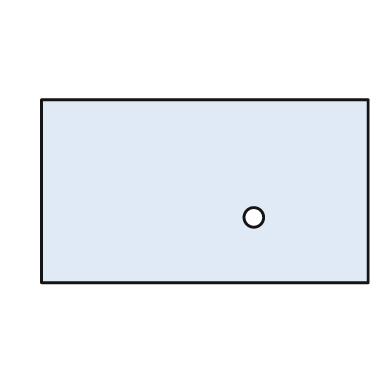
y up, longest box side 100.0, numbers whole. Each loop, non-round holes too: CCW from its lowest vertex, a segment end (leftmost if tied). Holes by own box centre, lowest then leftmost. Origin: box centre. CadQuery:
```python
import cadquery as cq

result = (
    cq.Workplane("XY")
    .moveTo(-50.0, -28.0)
    .lineTo(50.0, -28.0)
    .lineTo(50.0, 28.0)
    .lineTo(-50.0, 28.0)
    .close()
    .moveTo(15.0, -8.0)
    .circle(3.0)
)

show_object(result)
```